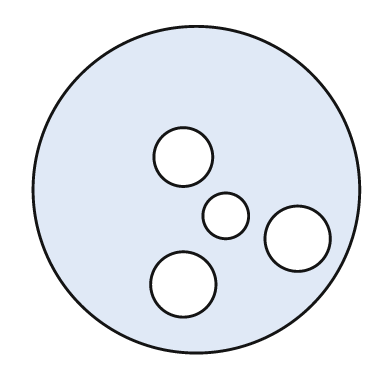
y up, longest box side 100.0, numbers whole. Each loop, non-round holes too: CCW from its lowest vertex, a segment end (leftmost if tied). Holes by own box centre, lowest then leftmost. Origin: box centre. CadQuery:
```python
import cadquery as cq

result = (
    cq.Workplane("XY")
    .moveTo(0.0, 0.0)
    .circle(50.0)
    .moveTo(-4.0, -29.0)
    .circle(10.0)
    .moveTo(31.0, -15.0)
    .circle(10.0)
    .moveTo(9.0, -8.0)
    .circle(7.0)
    .moveTo(-4.0, 10.0)
    .circle(9.0)
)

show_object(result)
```